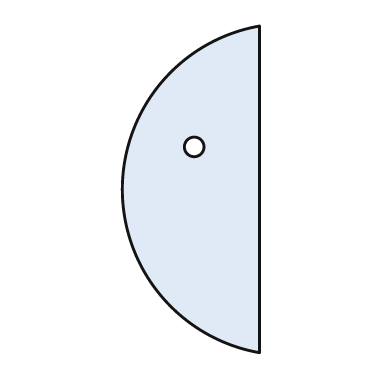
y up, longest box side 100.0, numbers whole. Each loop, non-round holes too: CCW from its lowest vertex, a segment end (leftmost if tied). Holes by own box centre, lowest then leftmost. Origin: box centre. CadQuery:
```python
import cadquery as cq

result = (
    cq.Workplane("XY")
    .moveTo(21.0, -50.0)
    .lineTo(21.0, 50.0)
    .threePointArc((-21.0, 0.0), (21.0, -50.0))
    .close()
    .moveTo(1.0, 13.0)
    .circle(3.0)
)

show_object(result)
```